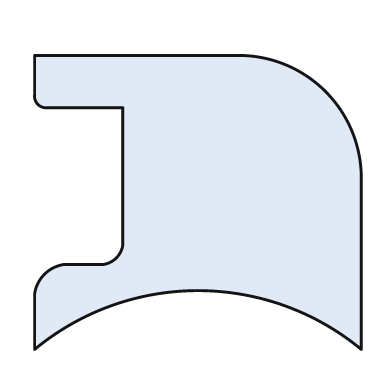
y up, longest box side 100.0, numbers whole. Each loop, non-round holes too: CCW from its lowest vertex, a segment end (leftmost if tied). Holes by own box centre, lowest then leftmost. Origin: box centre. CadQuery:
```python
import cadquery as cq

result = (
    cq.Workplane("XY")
    .moveTo(-50.0, -45.0)
    .threePointArc((0.0, -27.0), (50.0, -45.0))
    .lineTo(50.0, 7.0)
    .threePointArc((39.0, 34.0), (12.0, 45.0))
    .lineTo(-50.0, 45.0)
    .lineTo(-50.0, 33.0)
    .threePointArc((-49.0, 30.0), (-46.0, 29.0))
    .lineTo(-23.0, 29.0)
    .lineTo(-23.0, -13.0)
    .threePointArc((-25.0, -17.0), (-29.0, -19.0))
    .lineTo(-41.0, -19.0)
    .threePointArc((-47.0, -22.0), (-50.0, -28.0))
    .close()
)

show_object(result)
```